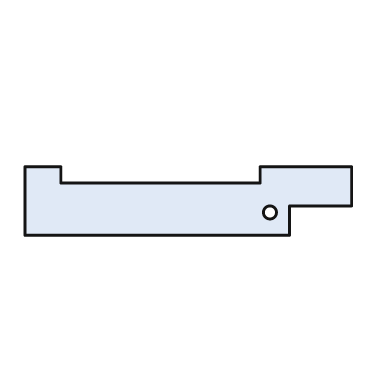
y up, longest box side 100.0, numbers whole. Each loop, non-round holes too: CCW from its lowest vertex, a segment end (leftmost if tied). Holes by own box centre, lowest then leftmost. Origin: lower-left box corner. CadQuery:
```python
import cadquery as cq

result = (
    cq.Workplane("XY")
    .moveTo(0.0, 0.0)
    .lineTo(81.0, 0.0)
    .lineTo(81.0, 9.0)
    .lineTo(100.0, 9.0)
    .lineTo(100.0, 21.0)
    .lineTo(72.0, 21.0)
    .lineTo(72.0, 16.0)
    .lineTo(11.0, 16.0)
    .lineTo(11.0, 21.0)
    .lineTo(0.0, 21.0)
    .close()
    .moveTo(75.0, 7.0)
    .circle(2.0)
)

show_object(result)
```